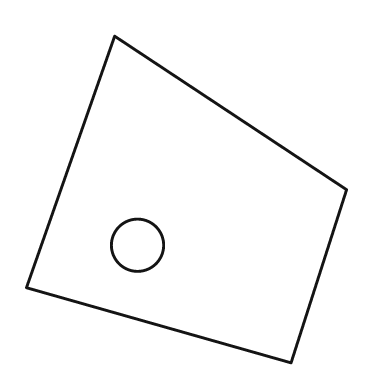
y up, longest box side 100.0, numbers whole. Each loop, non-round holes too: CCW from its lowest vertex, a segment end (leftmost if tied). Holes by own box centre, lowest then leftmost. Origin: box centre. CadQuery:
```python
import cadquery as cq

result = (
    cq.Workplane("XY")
    .moveTo(32.0, -50.0)
    .lineTo(49.0, 3.0)
    .lineTo(-22.0, 50.0)
    .lineTo(-49.0, -27.0)
    .close()
    .moveTo(-15.0, -14.0)
    .circle(8.0)
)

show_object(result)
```